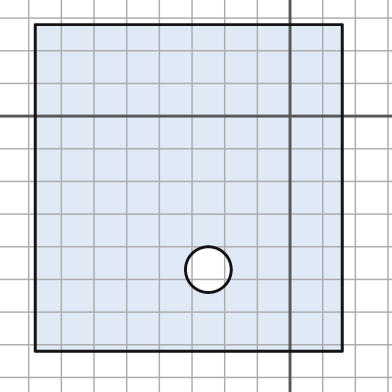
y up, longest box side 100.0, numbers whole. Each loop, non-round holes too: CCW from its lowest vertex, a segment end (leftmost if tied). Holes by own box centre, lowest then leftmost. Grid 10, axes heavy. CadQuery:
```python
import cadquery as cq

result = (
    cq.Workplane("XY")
    .moveTo(-78.0, -72.0)
    .lineTo(16.0, -72.0)
    .lineTo(16.0, 28.0)
    .lineTo(-78.0, 28.0)
    .close()
    .moveTo(-25.0, -47.0)
    .circle(7.0)
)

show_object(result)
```